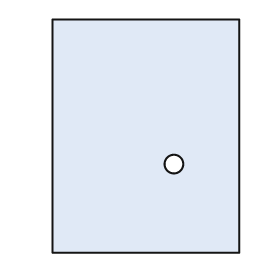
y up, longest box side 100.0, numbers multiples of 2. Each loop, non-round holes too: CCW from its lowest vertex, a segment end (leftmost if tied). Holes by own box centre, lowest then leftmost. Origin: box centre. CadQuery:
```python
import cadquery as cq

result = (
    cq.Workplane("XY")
    .moveTo(-40.0, -50.0)
    .lineTo(40.0, -50.0)
    .lineTo(40.0, 50.0)
    .lineTo(-40.0, 50.0)
    .close()
    .moveTo(12.0, -12.0)
    .circle(4.0)
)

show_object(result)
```